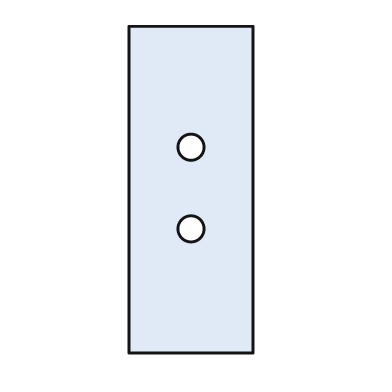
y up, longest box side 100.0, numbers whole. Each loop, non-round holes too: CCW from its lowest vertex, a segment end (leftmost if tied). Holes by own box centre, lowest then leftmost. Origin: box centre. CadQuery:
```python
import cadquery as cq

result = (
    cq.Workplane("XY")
    .moveTo(-19.0, -50.0)
    .lineTo(19.0, -50.0)
    .lineTo(19.0, 50.0)
    .lineTo(-19.0, 50.0)
    .close()
    .moveTo(0.0, -12.0)
    .circle(4.0)
    .moveTo(0.0, 13.0)
    .circle(4.0)
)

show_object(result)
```